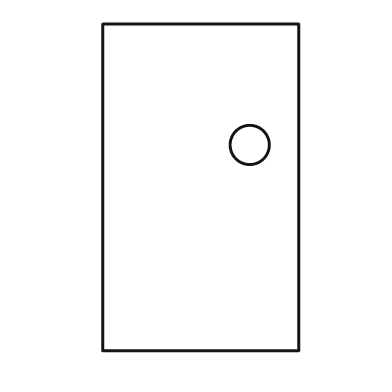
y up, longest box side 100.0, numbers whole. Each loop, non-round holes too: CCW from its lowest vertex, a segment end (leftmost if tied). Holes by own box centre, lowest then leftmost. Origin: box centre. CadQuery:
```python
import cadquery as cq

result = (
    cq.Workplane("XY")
    .moveTo(-30.0, -50.0)
    .lineTo(30.0, -50.0)
    .lineTo(30.0, 50.0)
    .lineTo(-30.0, 50.0)
    .close()
    .moveTo(15.0, 13.0)
    .circle(6.0)
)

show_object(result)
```